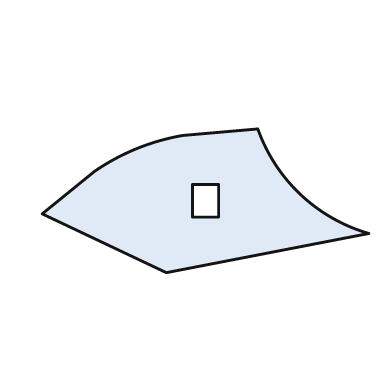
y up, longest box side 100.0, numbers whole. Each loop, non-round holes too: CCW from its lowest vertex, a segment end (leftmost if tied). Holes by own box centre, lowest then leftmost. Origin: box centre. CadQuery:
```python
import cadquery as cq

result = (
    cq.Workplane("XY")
    .moveTo(-12.0, -22.0)
    .lineTo(50.0, -10.0)
    .threePointArc((29.0, 2.0), (16.0, 22.0))
    .lineTo(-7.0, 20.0)
    .threePointArc((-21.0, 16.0), (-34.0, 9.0))
    .lineTo(-50.0, -4.0)
    .close()
    .moveTo(-4.0, -5.0)
    .lineTo(4.0, -5.0)
    .lineTo(4.0, 5.0)
    .lineTo(-4.0, 5.0)
    .close()
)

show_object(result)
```